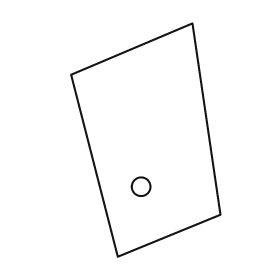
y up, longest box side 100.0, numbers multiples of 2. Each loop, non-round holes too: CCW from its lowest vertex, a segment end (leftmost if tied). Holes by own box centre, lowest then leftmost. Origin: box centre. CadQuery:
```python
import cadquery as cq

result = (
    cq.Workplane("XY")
    .moveTo(-12.0, -50.0)
    .lineTo(32.0, -32.0)
    .lineTo(20.0, 50.0)
    .lineTo(-32.0, 28.0)
    .close()
    .moveTo(-2.0, -20.0)
    .circle(4.0)
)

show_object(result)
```